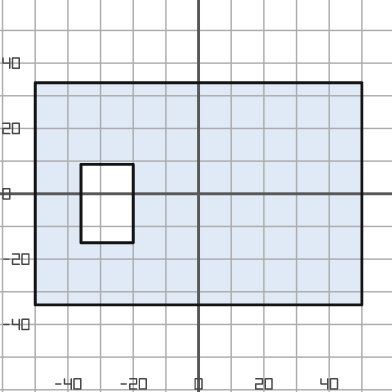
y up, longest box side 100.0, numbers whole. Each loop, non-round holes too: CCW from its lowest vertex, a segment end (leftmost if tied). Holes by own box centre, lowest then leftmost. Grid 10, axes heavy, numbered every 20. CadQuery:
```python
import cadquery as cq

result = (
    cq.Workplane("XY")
    .moveTo(-50.0, -34.0)
    .lineTo(50.0, -34.0)
    .lineTo(50.0, 34.0)
    .lineTo(-50.0, 34.0)
    .close()
    .moveTo(-36.0, -15.0)
    .lineTo(-20.0, -15.0)
    .lineTo(-20.0, 9.0)
    .lineTo(-36.0, 9.0)
    .close()
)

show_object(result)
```